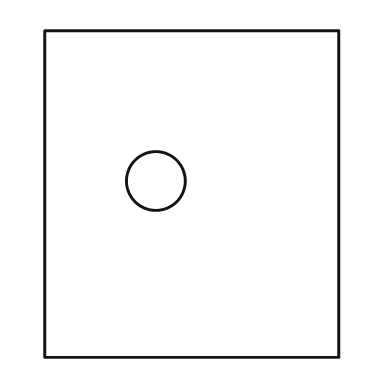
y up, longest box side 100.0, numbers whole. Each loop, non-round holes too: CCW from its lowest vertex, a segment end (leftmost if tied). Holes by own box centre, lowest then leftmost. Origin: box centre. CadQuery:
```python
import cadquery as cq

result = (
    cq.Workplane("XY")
    .moveTo(-45.0, -50.0)
    .lineTo(45.0, -50.0)
    .lineTo(45.0, 50.0)
    .lineTo(-45.0, 50.0)
    .close()
    .moveTo(-11.0, 4.0)
    .circle(9.0)
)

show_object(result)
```